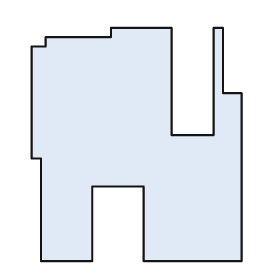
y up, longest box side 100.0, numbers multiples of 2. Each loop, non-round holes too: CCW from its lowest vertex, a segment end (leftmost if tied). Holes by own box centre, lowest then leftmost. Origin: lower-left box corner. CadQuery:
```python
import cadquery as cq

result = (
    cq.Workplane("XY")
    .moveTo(4.0, 0.0)
    .lineTo(26.0, 0.0)
    .lineTo(26.0, 32.0)
    .lineTo(48.0, 32.0)
    .lineTo(48.0, 0.0)
    .lineTo(90.0, 0.0)
    .lineTo(90.0, 72.0)
    .lineTo(82.0, 72.0)
    .lineTo(82.0, 100.0)
    .lineTo(78.0, 100.0)
    .lineTo(78.0, 54.0)
    .lineTo(60.0, 54.0)
    .lineTo(60.0, 100.0)
    .lineTo(34.0, 100.0)
    .lineTo(34.0, 96.0)
    .lineTo(6.0, 96.0)
    .lineTo(6.0, 92.0)
    .lineTo(0.0, 92.0)
    .lineTo(0.0, 44.0)
    .lineTo(4.0, 44.0)
    .close()
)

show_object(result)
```